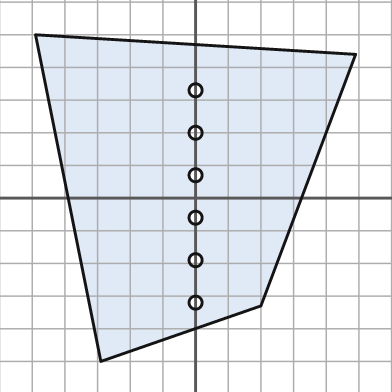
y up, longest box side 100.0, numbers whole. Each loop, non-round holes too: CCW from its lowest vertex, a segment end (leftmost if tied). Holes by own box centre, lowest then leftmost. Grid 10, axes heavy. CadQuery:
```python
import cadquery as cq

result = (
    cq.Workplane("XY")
    .moveTo(-29.0, -50.0)
    .lineTo(20.0, -33.0)
    .lineTo(49.0, 44.0)
    .lineTo(-49.0, 50.0)
    .close()
    .moveTo(0.0, -32.0)
    .circle(2.0)
    .moveTo(0.0, -19.0)
    .circle(2.0)
    .moveTo(0.0, -6.0)
    .circle(2.0)
    .moveTo(0.0, 7.0)
    .circle(2.0)
    .moveTo(0.0, 20.0)
    .circle(2.0)
    .moveTo(0.0, 33.0)
    .circle(2.0)
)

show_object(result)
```